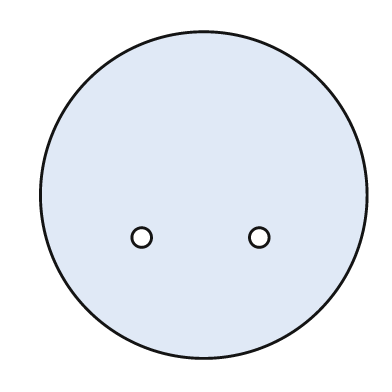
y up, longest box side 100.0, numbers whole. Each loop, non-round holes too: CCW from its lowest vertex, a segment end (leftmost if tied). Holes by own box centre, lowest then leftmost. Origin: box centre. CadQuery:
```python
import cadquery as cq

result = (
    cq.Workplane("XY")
    .moveTo(0.0, 0.0)
    .circle(50.0)
    .moveTo(-19.0, -13.0)
    .circle(3.0)
    .moveTo(17.0, -13.0)
    .circle(3.0)
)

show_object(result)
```